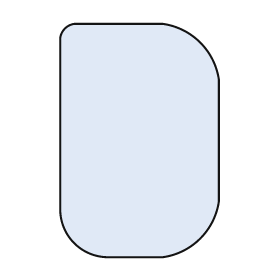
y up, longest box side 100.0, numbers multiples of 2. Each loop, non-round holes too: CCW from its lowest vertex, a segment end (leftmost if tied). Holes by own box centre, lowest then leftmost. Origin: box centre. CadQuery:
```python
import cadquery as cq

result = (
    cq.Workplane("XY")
    .moveTo(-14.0, -50.0)
    .lineTo(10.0, -50.0)
    .threePointArc((26.0, -42.0), (34.0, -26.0))
    .lineTo(34.0, 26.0)
    .threePointArc((26.0, 42.0), (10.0, 50.0))
    .lineTo(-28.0, 50.0)
    .threePointArc((-32.0, 48.0), (-34.0, 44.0))
    .lineTo(-34.0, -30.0)
    .threePointArc((-28.0, -44.0), (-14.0, -50.0))
    .close()
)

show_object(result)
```